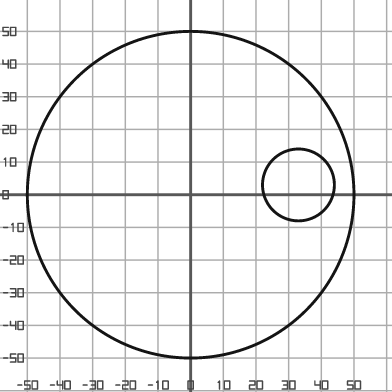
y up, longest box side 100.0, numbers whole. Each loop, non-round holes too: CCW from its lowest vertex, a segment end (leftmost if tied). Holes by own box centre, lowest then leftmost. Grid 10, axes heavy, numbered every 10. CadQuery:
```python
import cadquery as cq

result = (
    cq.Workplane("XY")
    .moveTo(0.0, 0.0)
    .circle(50.0)
    .moveTo(33.0, 3.0)
    .circle(11.0)
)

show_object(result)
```